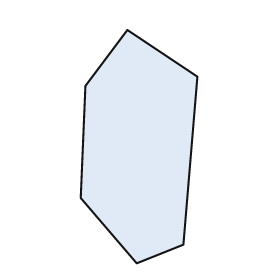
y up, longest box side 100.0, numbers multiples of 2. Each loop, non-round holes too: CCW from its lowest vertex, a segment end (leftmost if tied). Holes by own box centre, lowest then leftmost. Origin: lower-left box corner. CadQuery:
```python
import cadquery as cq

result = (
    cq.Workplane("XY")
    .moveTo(24.0, 0.0)
    .lineTo(44.0, 8.0)
    .lineTo(50.0, 80.0)
    .lineTo(20.0, 100.0)
    .lineTo(2.0, 76.0)
    .lineTo(0.0, 28.0)
    .close()
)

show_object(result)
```